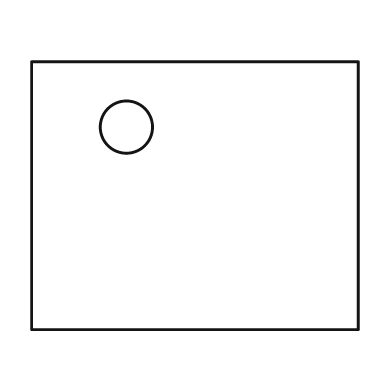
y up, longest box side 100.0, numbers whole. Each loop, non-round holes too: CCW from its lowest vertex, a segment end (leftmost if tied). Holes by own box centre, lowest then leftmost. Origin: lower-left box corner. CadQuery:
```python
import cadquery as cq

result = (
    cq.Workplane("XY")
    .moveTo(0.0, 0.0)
    .lineTo(100.0, 0.0)
    .lineTo(100.0, 82.0)
    .lineTo(0.0, 82.0)
    .close()
    .moveTo(29.0, 62.0)
    .circle(8.0)
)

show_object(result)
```